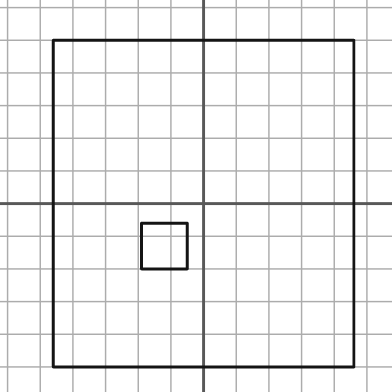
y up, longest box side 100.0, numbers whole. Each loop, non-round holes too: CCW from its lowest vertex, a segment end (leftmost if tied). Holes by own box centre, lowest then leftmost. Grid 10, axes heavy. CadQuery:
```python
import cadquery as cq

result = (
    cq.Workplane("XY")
    .moveTo(-46.0, -50.0)
    .lineTo(46.0, -50.0)
    .lineTo(46.0, 50.0)
    .lineTo(-46.0, 50.0)
    .close()
    .moveTo(-19.0, -20.0)
    .lineTo(-5.0, -20.0)
    .lineTo(-5.0, -6.0)
    .lineTo(-19.0, -6.0)
    .close()
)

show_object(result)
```